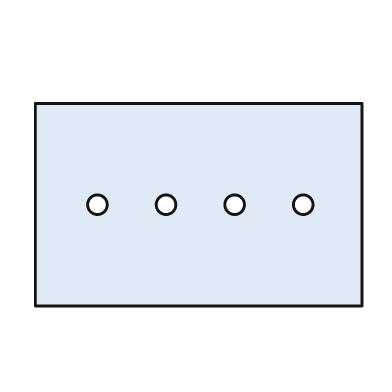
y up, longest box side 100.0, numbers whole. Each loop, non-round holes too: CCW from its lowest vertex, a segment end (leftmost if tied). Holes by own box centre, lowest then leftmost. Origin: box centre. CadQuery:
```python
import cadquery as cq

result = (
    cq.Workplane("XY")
    .moveTo(-50.0, -31.0)
    .lineTo(50.0, -31.0)
    .lineTo(50.0, 31.0)
    .lineTo(-50.0, 31.0)
    .close()
    .moveTo(-31.0, 0.0)
    .circle(3.0)
    .moveTo(-10.0, 0.0)
    .circle(3.0)
    .moveTo(11.0, 0.0)
    .circle(3.0)
    .moveTo(32.0, 0.0)
    .circle(3.0)
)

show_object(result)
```